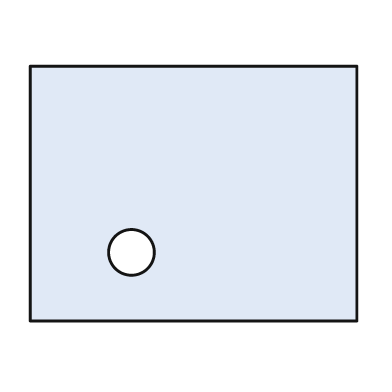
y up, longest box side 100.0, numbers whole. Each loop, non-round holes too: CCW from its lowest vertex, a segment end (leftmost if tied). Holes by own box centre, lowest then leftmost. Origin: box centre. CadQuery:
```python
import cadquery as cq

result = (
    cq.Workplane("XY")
    .moveTo(-50.0, -39.0)
    .lineTo(50.0, -39.0)
    .lineTo(50.0, 39.0)
    .lineTo(-50.0, 39.0)
    .close()
    .moveTo(-19.0, -18.0)
    .circle(7.0)
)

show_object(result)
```